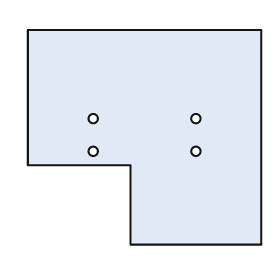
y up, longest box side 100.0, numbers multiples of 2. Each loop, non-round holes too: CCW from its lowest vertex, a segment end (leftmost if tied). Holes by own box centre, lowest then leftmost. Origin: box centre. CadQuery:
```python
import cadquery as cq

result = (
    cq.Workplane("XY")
    .moveTo(-6.0, -46.0)
    .lineTo(50.0, -46.0)
    .lineTo(50.0, 46.0)
    .lineTo(-50.0, 46.0)
    .lineTo(-50.0, -12.0)
    .lineTo(-6.0, -12.0)
    .close()
    .moveTo(-22.0, -6.0)
    .circle(2.0)
    .moveTo(22.0, -6.0)
    .circle(2.0)
    .moveTo(-22.0, 8.0)
    .circle(2.0)
    .moveTo(22.0, 8.0)
    .circle(2.0)
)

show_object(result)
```